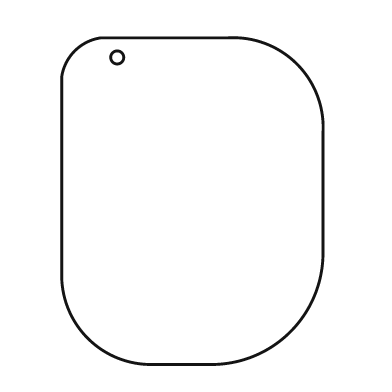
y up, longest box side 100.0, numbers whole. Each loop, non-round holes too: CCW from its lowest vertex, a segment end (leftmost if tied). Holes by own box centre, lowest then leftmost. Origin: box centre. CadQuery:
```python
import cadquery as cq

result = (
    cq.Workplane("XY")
    .moveTo(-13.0, -50.0)
    .lineTo(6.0, -50.0)
    .threePointArc((30.0, -40.0), (40.0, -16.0))
    .lineTo(40.0, 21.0)
    .threePointArc((32.0, 42.0), (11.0, 50.0))
    .lineTo(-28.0, 50.0)
    .threePointArc((-36.0, 46.0), (-40.0, 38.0))
    .lineTo(-40.0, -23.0)
    .threePointArc((-32.0, -42.0), (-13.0, -50.0))
    .close()
    .moveTo(-23.0, 44.0)
    .circle(2.0)
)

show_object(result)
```